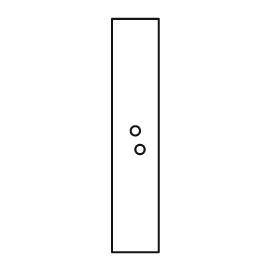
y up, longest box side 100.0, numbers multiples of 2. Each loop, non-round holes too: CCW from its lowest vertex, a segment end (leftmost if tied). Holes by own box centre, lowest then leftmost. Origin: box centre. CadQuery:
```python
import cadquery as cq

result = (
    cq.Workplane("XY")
    .moveTo(-10.0, -50.0)
    .lineTo(10.0, -50.0)
    .lineTo(10.0, 50.0)
    .lineTo(-10.0, 50.0)
    .close()
    .moveTo(2.0, -6.0)
    .circle(2.0)
    .moveTo(0.0, 2.0)
    .circle(2.0)
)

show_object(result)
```